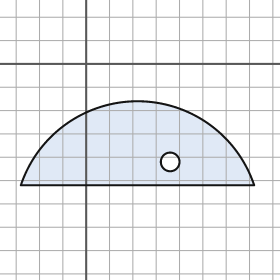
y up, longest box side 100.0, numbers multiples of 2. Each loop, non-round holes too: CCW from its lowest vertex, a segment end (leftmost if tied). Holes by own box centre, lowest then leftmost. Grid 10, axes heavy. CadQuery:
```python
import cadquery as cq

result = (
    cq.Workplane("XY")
    .moveTo(-28.0, -52.0)
    .lineTo(72.0, -52.0)
    .threePointArc((22.0, -16.0), (-28.0, -52.0))
    .close()
    .moveTo(36.0, -42.0)
    .circle(4.0)
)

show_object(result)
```